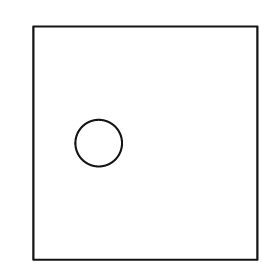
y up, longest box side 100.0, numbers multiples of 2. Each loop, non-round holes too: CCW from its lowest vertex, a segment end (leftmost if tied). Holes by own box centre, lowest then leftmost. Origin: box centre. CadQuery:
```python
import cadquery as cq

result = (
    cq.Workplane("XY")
    .moveTo(-48.0, -50.0)
    .lineTo(48.0, -50.0)
    .lineTo(48.0, 50.0)
    .lineTo(-48.0, 50.0)
    .close()
    .moveTo(-20.0, 0.0)
    .circle(10.0)
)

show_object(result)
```